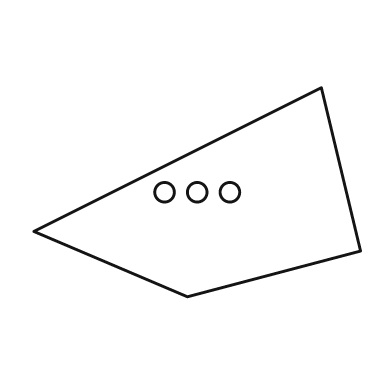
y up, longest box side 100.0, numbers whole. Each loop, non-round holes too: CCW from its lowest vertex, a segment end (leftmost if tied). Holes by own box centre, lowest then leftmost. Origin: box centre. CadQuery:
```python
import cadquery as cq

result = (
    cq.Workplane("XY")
    .moveTo(-3.0, -32.0)
    .lineTo(50.0, -18.0)
    .lineTo(38.0, 32.0)
    .lineTo(-50.0, -12.0)
    .close()
    .moveTo(-10.0, 0.0)
    .circle(3.0)
    .moveTo(0.0, 0.0)
    .circle(3.0)
    .moveTo(10.0, 0.0)
    .circle(3.0)
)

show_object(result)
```